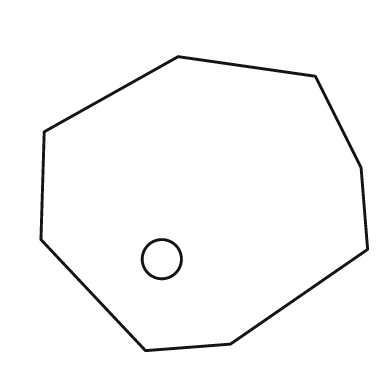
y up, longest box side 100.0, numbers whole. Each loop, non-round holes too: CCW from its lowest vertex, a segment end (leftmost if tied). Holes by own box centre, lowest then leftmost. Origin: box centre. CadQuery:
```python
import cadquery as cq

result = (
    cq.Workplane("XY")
    .moveTo(-18.0, -45.0)
    .lineTo(8.0, -43.0)
    .lineTo(50.0, -14.0)
    .lineTo(48.0, 11.0)
    .lineTo(34.0, 39.0)
    .lineTo(-8.0, 45.0)
    .lineTo(-49.0, 22.0)
    .lineTo(-50.0, -11.0)
    .close()
    .moveTo(-13.0, -17.0)
    .circle(6.0)
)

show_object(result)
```